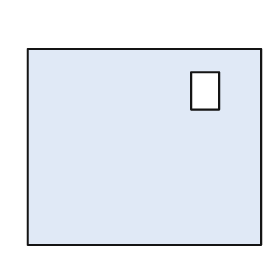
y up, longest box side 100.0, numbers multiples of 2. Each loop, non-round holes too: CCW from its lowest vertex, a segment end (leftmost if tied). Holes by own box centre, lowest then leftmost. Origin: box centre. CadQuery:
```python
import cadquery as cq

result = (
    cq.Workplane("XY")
    .moveTo(-50.0, -42.0)
    .lineTo(50.0, -42.0)
    .lineTo(50.0, 42.0)
    .lineTo(-50.0, 42.0)
    .close()
    .moveTo(20.0, 16.0)
    .lineTo(32.0, 16.0)
    .lineTo(32.0, 32.0)
    .lineTo(20.0, 32.0)
    .close()
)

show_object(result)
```